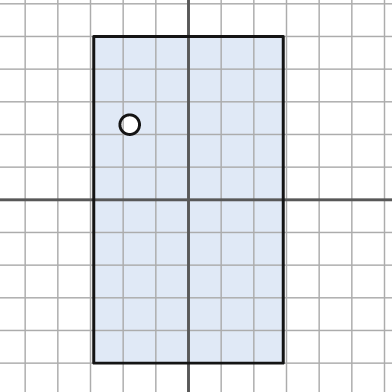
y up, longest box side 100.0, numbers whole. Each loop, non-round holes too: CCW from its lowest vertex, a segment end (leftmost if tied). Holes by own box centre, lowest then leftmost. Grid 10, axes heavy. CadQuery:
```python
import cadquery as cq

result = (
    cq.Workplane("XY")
    .moveTo(-29.0, -50.0)
    .lineTo(29.0, -50.0)
    .lineTo(29.0, 50.0)
    .lineTo(-29.0, 50.0)
    .close()
    .moveTo(-18.0, 23.0)
    .circle(3.0)
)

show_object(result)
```